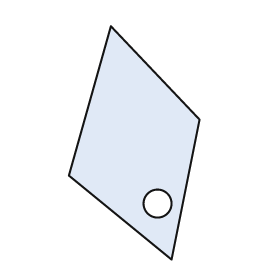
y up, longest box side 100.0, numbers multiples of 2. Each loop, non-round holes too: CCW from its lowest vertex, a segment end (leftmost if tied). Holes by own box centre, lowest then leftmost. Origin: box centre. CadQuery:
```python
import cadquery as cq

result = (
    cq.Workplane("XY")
    .moveTo(16.0, -50.0)
    .lineTo(28.0, 10.0)
    .lineTo(-10.0, 50.0)
    .lineTo(-28.0, -14.0)
    .close()
    .moveTo(10.0, -26.0)
    .circle(6.0)
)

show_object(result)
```